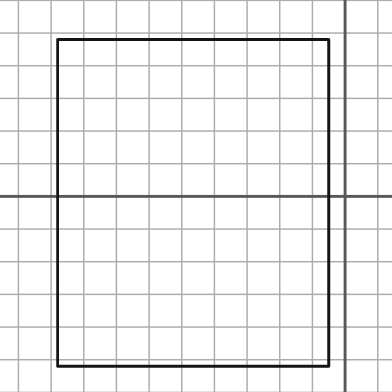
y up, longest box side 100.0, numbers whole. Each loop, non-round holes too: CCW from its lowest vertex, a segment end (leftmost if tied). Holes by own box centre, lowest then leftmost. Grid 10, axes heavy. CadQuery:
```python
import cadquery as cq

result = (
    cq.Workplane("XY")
    .moveTo(-88.0, -52.0)
    .lineTo(-5.0, -52.0)
    .lineTo(-5.0, 48.0)
    .lineTo(-88.0, 48.0)
    .close()
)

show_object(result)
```